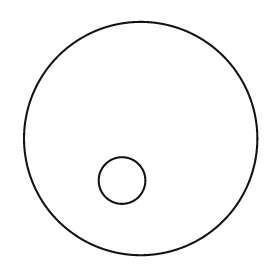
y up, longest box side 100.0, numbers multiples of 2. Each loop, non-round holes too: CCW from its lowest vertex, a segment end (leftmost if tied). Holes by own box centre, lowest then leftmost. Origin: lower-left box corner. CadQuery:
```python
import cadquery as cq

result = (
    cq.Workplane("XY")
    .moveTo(50.0, 50.0)
    .circle(50.0)
    .moveTo(42.0, 32.0)
    .circle(10.0)
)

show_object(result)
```